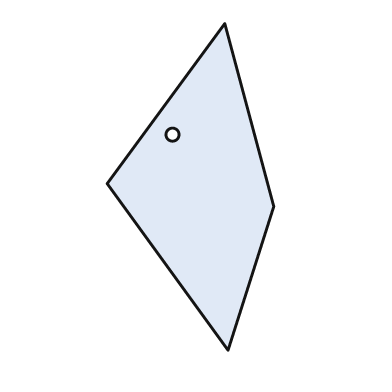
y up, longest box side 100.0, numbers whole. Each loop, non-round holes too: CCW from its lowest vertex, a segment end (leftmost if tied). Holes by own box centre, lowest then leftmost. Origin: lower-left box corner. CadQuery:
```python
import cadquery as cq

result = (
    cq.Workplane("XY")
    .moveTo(37.0, 0.0)
    .lineTo(51.0, 44.0)
    .lineTo(36.0, 100.0)
    .lineTo(0.0, 51.0)
    .close()
    .moveTo(20.0, 66.0)
    .circle(2.0)
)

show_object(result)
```